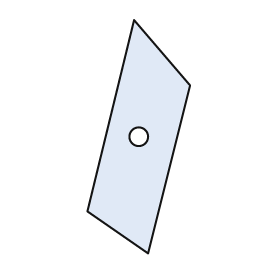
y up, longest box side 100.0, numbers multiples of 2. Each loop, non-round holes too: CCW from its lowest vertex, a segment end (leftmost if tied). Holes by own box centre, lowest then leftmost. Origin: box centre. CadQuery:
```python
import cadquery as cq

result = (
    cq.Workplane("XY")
    .moveTo(4.0, -50.0)
    .lineTo(22.0, 22.0)
    .lineTo(-2.0, 50.0)
    .lineTo(-22.0, -32.0)
    .close()
    .moveTo(0.0, 0.0)
    .circle(4.0)
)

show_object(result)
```